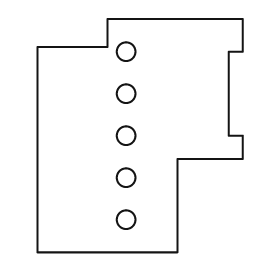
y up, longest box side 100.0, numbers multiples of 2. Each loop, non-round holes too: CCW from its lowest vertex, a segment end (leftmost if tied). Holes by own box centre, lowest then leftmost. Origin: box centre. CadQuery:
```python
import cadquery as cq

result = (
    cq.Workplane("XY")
    .moveTo(-44.0, -50.0)
    .lineTo(16.0, -50.0)
    .lineTo(16.0, -10.0)
    .lineTo(44.0, -10.0)
    .lineTo(44.0, 0.0)
    .lineTo(38.0, 0.0)
    .lineTo(38.0, 36.0)
    .lineTo(44.0, 36.0)
    .lineTo(44.0, 50.0)
    .lineTo(-14.0, 50.0)
    .lineTo(-14.0, 38.0)
    .lineTo(-44.0, 38.0)
    .close()
    .moveTo(-6.0, -36.0)
    .circle(4.0)
    .moveTo(-6.0, -18.0)
    .circle(4.0)
    .moveTo(-6.0, 0.0)
    .circle(4.0)
    .moveTo(-6.0, 18.0)
    .circle(4.0)
    .moveTo(-6.0, 36.0)
    .circle(4.0)
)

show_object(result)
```